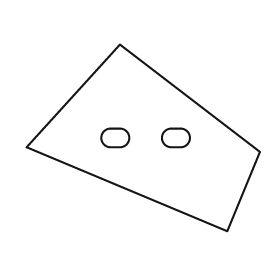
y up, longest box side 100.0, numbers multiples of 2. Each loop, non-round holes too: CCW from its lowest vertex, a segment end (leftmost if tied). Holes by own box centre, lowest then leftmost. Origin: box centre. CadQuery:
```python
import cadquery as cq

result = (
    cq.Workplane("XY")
    .moveTo(36.0, -40.0)
    .lineTo(50.0, -6.0)
    .lineTo(-10.0, 40.0)
    .lineTo(-50.0, -4.0)
    .close()
    .moveTo(-14.0, -4.0)
    .lineTo(-10.0, -4.0)
    .threePointArc((-6.0, 0.0), (-10.0, 4.0))
    .lineTo(-14.0, 4.0)
    .threePointArc((-18.0, 0.0), (-14.0, -4.0))
    .close()
    .moveTo(12.0, -4.0)
    .lineTo(16.0, -4.0)
    .threePointArc((20.0, 0.0), (16.0, 4.0))
    .lineTo(12.0, 4.0)
    .threePointArc((8.0, 0.0), (12.0, -4.0))
    .close()
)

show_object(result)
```